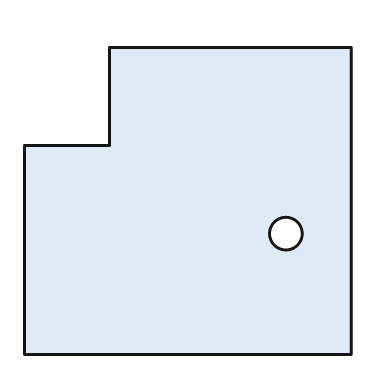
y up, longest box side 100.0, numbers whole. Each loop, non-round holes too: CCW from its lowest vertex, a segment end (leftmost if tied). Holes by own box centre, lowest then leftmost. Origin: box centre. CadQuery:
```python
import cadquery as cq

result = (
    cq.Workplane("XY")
    .moveTo(-50.0, -47.0)
    .lineTo(50.0, -47.0)
    .lineTo(50.0, 47.0)
    .lineTo(-24.0, 47.0)
    .lineTo(-24.0, 17.0)
    .lineTo(-50.0, 17.0)
    .close()
    .moveTo(30.0, -10.0)
    .circle(5.0)
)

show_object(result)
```